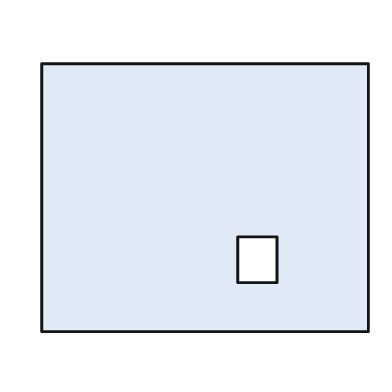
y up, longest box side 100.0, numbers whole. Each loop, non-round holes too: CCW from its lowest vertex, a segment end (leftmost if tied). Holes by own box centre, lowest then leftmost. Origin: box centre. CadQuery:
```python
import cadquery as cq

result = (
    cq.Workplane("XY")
    .moveTo(-50.0, -41.0)
    .lineTo(50.0, -41.0)
    .lineTo(50.0, 41.0)
    .lineTo(-50.0, 41.0)
    .close()
    .moveTo(10.0, -26.0)
    .lineTo(22.0, -26.0)
    .lineTo(22.0, -12.0)
    .lineTo(10.0, -12.0)
    .close()
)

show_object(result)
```